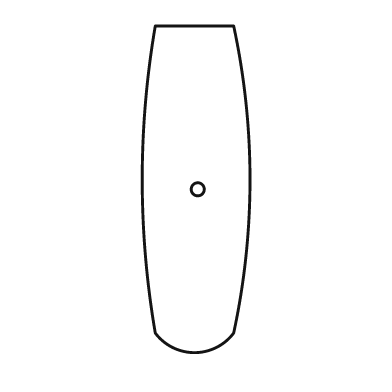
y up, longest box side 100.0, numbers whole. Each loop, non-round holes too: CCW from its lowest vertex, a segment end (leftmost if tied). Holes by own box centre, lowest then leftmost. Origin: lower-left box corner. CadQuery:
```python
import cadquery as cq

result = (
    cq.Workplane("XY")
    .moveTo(4.0, 6.0)
    .threePointArc((16.0, 0.0), (28.0, 6.0))
    .threePointArc((33.0, 53.0), (28.0, 100.0))
    .lineTo(4.0, 100.0)
    .threePointArc((0.0, 53.0), (4.0, 6.0))
    .close()
    .moveTo(17.0, 50.0)
    .circle(2.0)
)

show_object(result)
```